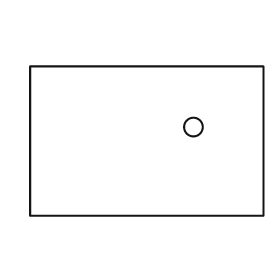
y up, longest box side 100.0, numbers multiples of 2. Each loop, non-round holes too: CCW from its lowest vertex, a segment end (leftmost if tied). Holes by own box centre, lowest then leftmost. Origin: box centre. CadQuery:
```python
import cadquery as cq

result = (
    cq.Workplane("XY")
    .moveTo(-50.0, -32.0)
    .lineTo(50.0, -32.0)
    .lineTo(50.0, 32.0)
    .lineTo(-50.0, 32.0)
    .close()
    .moveTo(20.0, 6.0)
    .circle(4.0)
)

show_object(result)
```